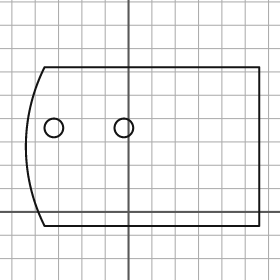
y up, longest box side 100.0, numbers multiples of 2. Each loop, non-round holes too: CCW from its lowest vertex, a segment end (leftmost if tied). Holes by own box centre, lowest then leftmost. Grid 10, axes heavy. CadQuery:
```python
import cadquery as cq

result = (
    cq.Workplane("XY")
    .moveTo(-36.0, -6.0)
    .lineTo(56.0, -6.0)
    .lineTo(56.0, 62.0)
    .lineTo(-36.0, 62.0)
    .threePointArc((-44.0, 28.0), (-36.0, -6.0))
    .close()
    .moveTo(-32.0, 36.0)
    .circle(4.0)
    .moveTo(-2.0, 36.0)
    .circle(4.0)
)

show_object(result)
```